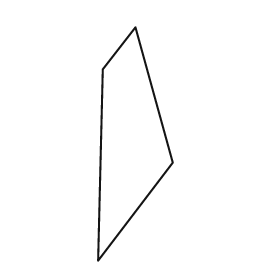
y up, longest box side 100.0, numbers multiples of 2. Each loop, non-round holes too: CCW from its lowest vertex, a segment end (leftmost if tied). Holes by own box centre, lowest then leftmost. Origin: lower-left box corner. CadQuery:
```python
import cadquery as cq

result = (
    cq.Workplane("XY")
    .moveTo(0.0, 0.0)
    .lineTo(32.0, 42.0)
    .lineTo(16.0, 100.0)
    .lineTo(2.0, 82.0)
    .close()
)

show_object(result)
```